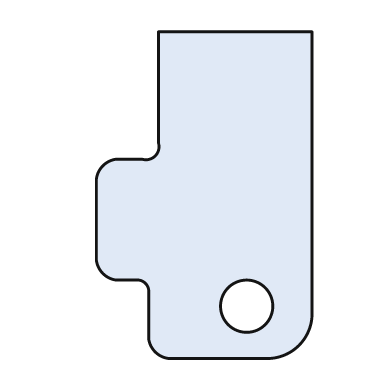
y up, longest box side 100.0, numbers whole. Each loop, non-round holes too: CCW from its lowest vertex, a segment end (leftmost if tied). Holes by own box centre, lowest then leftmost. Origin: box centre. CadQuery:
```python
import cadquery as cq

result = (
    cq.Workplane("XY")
    .moveTo(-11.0, -50.0)
    .lineTo(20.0, -50.0)
    .threePointArc((29.0, -46.0), (33.0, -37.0))
    .lineTo(33.0, 50.0)
    .lineTo(-14.0, 50.0)
    .lineTo(-14.0, 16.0)
    .threePointArc((-15.0, 12.0), (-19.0, 11.0))
    .lineTo(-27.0, 11.0)
    .threePointArc((-31.0, 9.0), (-33.0, 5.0))
    .lineTo(-33.0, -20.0)
    .threePointArc((-31.0, -24.0), (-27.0, -26.0))
    .lineTo(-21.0, -26.0)
    .threePointArc((-18.0, -27.0), (-17.0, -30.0))
    .lineTo(-17.0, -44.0)
    .threePointArc((-15.0, -48.0), (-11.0, -50.0))
    .close()
    .moveTo(13.0, -34.0)
    .circle(8.0)
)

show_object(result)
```